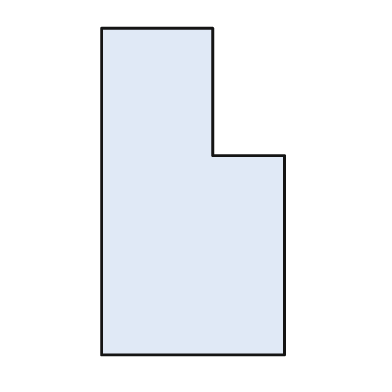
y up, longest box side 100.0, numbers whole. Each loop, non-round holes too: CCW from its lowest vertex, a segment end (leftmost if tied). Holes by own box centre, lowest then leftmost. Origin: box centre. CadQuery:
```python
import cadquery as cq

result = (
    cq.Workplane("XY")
    .moveTo(-28.0, -50.0)
    .lineTo(28.0, -50.0)
    .lineTo(28.0, 11.0)
    .lineTo(6.0, 11.0)
    .lineTo(6.0, 50.0)
    .lineTo(-28.0, 50.0)
    .close()
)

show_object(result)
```